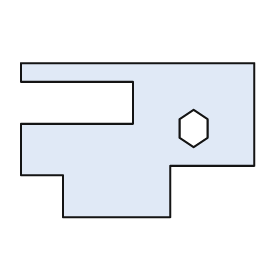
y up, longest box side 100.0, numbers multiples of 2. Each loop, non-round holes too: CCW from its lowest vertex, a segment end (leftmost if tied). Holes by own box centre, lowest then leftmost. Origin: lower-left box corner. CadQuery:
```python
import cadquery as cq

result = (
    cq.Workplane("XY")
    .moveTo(18.0, 0.0)
    .lineTo(64.0, 0.0)
    .lineTo(64.0, 22.0)
    .lineTo(100.0, 22.0)
    .lineTo(100.0, 66.0)
    .lineTo(0.0, 66.0)
    .lineTo(0.0, 58.0)
    .lineTo(48.0, 58.0)
    .lineTo(48.0, 40.0)
    .lineTo(0.0, 40.0)
    .lineTo(0.0, 18.0)
    .lineTo(18.0, 18.0)
    .close()
    .moveTo(74.0, 30.0)
    .lineTo(80.0, 34.0)
    .lineTo(80.0, 42.0)
    .lineTo(74.0, 46.0)
    .lineTo(68.0, 42.0)
    .lineTo(68.0, 34.0)
    .close()
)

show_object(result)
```